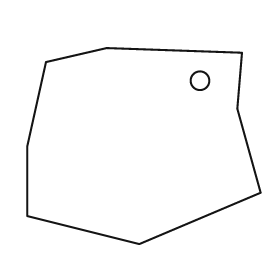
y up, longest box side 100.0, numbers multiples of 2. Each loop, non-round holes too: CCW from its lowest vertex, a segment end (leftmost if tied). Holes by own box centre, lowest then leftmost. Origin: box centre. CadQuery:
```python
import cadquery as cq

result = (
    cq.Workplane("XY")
    .moveTo(-2.0, -42.0)
    .lineTo(50.0, -20.0)
    .lineTo(40.0, 16.0)
    .lineTo(42.0, 40.0)
    .lineTo(-16.0, 42.0)
    .lineTo(-42.0, 36.0)
    .lineTo(-50.0, 0.0)
    .lineTo(-50.0, -30.0)
    .close()
    .moveTo(24.0, 28.0)
    .circle(4.0)
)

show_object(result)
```